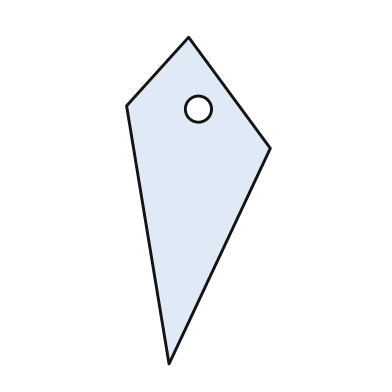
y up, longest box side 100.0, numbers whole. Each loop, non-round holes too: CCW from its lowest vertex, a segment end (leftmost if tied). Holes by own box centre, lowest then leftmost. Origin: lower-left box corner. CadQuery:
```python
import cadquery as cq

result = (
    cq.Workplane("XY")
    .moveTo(13.0, 0.0)
    .lineTo(44.0, 66.0)
    .lineTo(19.0, 100.0)
    .lineTo(0.0, 79.0)
    .close()
    .moveTo(22.0, 78.0)
    .circle(4.0)
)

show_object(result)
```